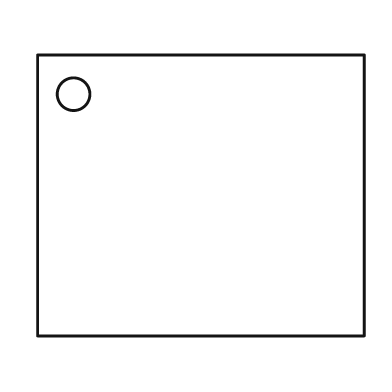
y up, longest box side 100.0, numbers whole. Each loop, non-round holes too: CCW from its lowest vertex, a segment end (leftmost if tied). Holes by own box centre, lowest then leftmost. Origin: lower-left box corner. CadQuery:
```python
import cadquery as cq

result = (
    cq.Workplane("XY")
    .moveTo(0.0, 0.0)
    .lineTo(100.0, 0.0)
    .lineTo(100.0, 86.0)
    .lineTo(0.0, 86.0)
    .close()
    .moveTo(11.0, 74.0)
    .circle(5.0)
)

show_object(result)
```